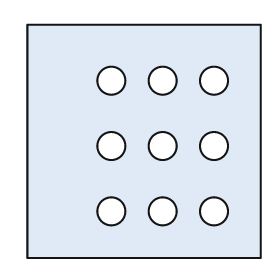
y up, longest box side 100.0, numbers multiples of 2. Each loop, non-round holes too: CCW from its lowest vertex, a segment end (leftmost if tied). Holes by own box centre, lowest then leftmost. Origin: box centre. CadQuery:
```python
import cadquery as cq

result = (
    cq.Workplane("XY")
    .moveTo(-50.0, -50.0)
    .lineTo(50.0, -50.0)
    .lineTo(50.0, 50.0)
    .lineTo(-50.0, 50.0)
    .close()
    .moveTo(-14.0, -30.0)
    .circle(6.0)
    .moveTo(8.0, -30.0)
    .circle(6.0)
    .moveTo(30.0, -30.0)
    .circle(6.0)
    .moveTo(-14.0, -2.0)
    .circle(6.0)
    .moveTo(8.0, -2.0)
    .circle(6.0)
    .moveTo(30.0, -2.0)
    .circle(6.0)
    .moveTo(-14.0, 26.0)
    .circle(6.0)
    .moveTo(8.0, 26.0)
    .circle(6.0)
    .moveTo(30.0, 26.0)
    .circle(6.0)
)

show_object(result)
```